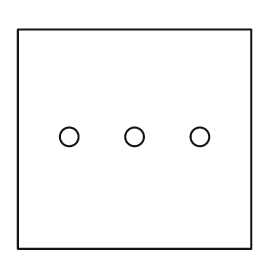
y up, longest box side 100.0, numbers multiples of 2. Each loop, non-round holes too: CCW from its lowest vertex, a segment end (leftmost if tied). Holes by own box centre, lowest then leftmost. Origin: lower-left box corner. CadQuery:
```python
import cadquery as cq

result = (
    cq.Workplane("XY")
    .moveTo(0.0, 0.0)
    .lineTo(100.0, 0.0)
    .lineTo(100.0, 94.0)
    .lineTo(0.0, 94.0)
    .close()
    .moveTo(22.0, 48.0)
    .circle(4.0)
    .moveTo(50.0, 48.0)
    .circle(4.0)
    .moveTo(78.0, 48.0)
    .circle(4.0)
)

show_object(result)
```